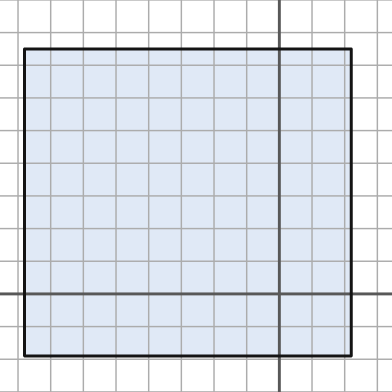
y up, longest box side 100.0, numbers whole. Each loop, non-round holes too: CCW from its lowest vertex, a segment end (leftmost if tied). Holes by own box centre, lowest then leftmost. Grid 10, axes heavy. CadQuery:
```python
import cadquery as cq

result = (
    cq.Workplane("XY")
    .moveTo(-78.0, -19.0)
    .lineTo(22.0, -19.0)
    .lineTo(22.0, 75.0)
    .lineTo(-78.0, 75.0)
    .close()
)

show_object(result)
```